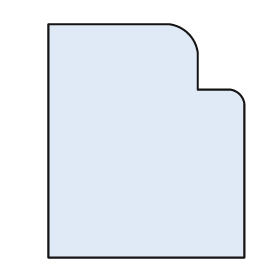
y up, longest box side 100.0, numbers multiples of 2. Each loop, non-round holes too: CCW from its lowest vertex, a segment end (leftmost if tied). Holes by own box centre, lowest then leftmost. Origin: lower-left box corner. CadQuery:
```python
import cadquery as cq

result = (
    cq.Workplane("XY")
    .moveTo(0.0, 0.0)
    .lineTo(84.0, 0.0)
    .lineTo(84.0, 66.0)
    .threePointArc((82.0, 70.0), (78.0, 72.0))
    .lineTo(64.0, 72.0)
    .lineTo(64.0, 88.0)
    .threePointArc((60.0, 96.0), (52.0, 100.0))
    .lineTo(0.0, 100.0)
    .close()
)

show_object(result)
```